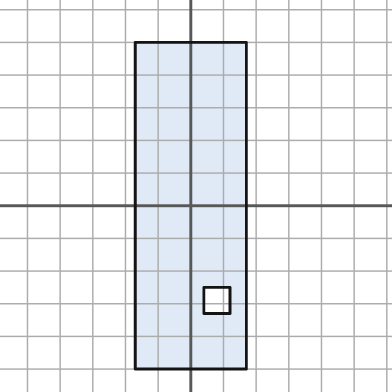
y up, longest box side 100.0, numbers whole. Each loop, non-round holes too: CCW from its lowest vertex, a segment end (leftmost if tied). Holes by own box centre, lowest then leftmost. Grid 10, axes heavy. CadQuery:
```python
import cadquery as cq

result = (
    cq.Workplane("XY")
    .moveTo(-17.0, -50.0)
    .lineTo(17.0, -50.0)
    .lineTo(17.0, 50.0)
    .lineTo(-17.0, 50.0)
    .close()
    .moveTo(4.0, -33.0)
    .lineTo(12.0, -33.0)
    .lineTo(12.0, -25.0)
    .lineTo(4.0, -25.0)
    .close()
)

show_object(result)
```